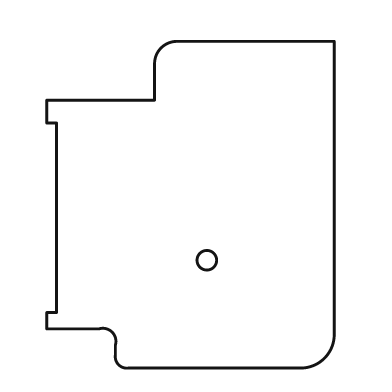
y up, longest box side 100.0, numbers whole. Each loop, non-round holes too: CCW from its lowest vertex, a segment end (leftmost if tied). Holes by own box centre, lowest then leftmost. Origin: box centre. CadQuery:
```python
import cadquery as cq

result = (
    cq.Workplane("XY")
    .moveTo(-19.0, -50.0)
    .lineTo(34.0, -50.0)
    .threePointArc((41.0, -47.0), (44.0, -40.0))
    .lineTo(44.0, 50.0)
    .lineTo(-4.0, 50.0)
    .threePointArc((-9.0, 48.0), (-11.0, 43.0))
    .lineTo(-11.0, 32.0)
    .lineTo(-44.0, 32.0)
    .lineTo(-44.0, 25.0)
    .lineTo(-41.0, 25.0)
    .lineTo(-41.0, -33.0)
    .lineTo(-44.0, -33.0)
    .lineTo(-44.0, -38.0)
    .lineTo(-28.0, -38.0)
    .threePointArc((-24.0, -39.0), (-23.0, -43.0))
    .lineTo(-23.0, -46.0)
    .threePointArc((-22.0, -49.0), (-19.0, -50.0))
    .close()
    .moveTo(5.0, -17.0)
    .circle(3.0)
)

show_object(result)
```